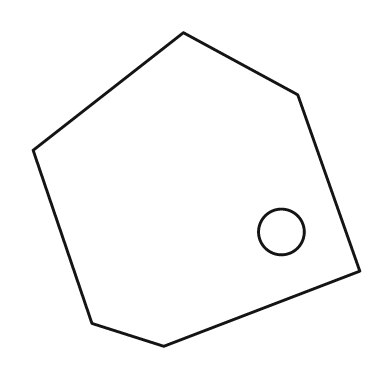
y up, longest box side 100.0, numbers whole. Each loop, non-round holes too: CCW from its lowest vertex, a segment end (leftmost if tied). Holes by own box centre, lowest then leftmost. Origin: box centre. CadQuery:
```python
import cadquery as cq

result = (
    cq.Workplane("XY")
    .moveTo(-10.0, -48.0)
    .lineTo(50.0, -25.0)
    .lineTo(31.0, 29.0)
    .lineTo(-4.0, 48.0)
    .lineTo(-50.0, 12.0)
    .lineTo(-32.0, -41.0)
    .close()
    .moveTo(26.0, -13.0)
    .circle(7.0)
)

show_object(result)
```